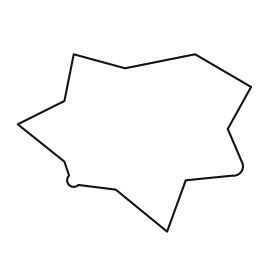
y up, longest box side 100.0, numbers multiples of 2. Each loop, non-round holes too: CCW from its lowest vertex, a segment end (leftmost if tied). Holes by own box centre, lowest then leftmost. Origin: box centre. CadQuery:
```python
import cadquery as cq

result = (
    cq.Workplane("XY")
    .moveTo(14.0, -38.0)
    .lineTo(22.0, -16.0)
    .lineTo(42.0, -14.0)
    .threePointArc((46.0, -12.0), (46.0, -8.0))
    .lineTo(40.0, 6.0)
    .lineTo(50.0, 24.0)
    .lineTo(26.0, 38.0)
    .lineTo(-4.0, 32.0)
    .lineTo(-26.0, 38.0)
    .lineTo(-30.0, 18.0)
    .lineTo(-50.0, 8.0)
    .lineTo(-30.0, -8.0)
    .lineTo(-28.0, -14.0)
    .threePointArc((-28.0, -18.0), (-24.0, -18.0))
    .lineTo(-8.0, -20.0)
    .close()
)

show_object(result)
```